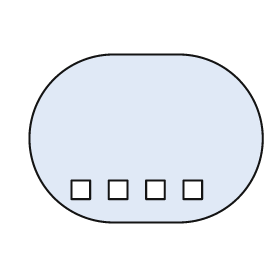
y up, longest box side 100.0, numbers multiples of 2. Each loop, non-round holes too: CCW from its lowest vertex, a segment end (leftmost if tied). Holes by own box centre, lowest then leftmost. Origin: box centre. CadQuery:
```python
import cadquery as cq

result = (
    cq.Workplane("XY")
    .moveTo(-14.0, -36.0)
    .lineTo(14.0, -36.0)
    .threePointArc((50.0, 0.0), (14.0, 36.0))
    .lineTo(-14.0, 36.0)
    .threePointArc((-50.0, 0.0), (-14.0, -36.0))
    .close()
    .moveTo(-32.0, -26.0)
    .lineTo(-24.0, -26.0)
    .lineTo(-24.0, -18.0)
    .lineTo(-32.0, -18.0)
    .close()
    .moveTo(-16.0, -26.0)
    .lineTo(-8.0, -26.0)
    .lineTo(-8.0, -18.0)
    .lineTo(-16.0, -18.0)
    .close()
    .moveTo(0.0, -26.0)
    .lineTo(8.0, -26.0)
    .lineTo(8.0, -18.0)
    .lineTo(0.0, -18.0)
    .close()
    .moveTo(16.0, -26.0)
    .lineTo(24.0, -26.0)
    .lineTo(24.0, -18.0)
    .lineTo(16.0, -18.0)
    .close()
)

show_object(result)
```